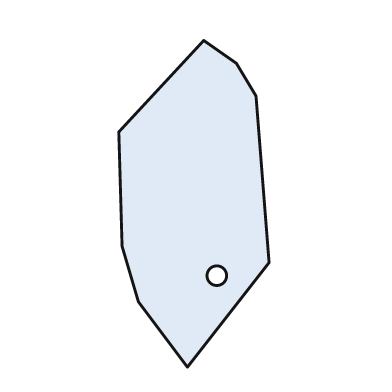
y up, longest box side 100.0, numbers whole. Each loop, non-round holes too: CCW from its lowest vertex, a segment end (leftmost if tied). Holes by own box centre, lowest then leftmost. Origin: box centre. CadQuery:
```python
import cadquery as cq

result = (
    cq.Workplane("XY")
    .moveTo(-2.0, -50.0)
    .lineTo(23.0, -18.0)
    .lineTo(19.0, 33.0)
    .lineTo(13.0, 43.0)
    .lineTo(3.0, 50.0)
    .lineTo(-23.0, 22.0)
    .lineTo(-22.0, -13.0)
    .lineTo(-17.0, -30.0)
    .close()
    .moveTo(7.0, -22.0)
    .circle(3.0)
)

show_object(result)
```